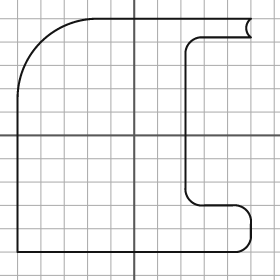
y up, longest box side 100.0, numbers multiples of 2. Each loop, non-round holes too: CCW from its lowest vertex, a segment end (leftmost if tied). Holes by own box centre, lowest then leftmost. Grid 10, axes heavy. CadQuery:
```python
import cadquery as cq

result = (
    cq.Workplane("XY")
    .moveTo(-50.0, -50.0)
    .lineTo(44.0, -50.0)
    .threePointArc((48.0, -48.0), (50.0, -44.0))
    .lineTo(50.0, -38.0)
    .threePointArc((48.0, -32.0), (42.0, -30.0))
    .lineTo(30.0, -30.0)
    .threePointArc((24.0, -28.0), (22.0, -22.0))
    .lineTo(22.0, 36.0)
    .threePointArc((24.0, 40.0), (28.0, 42.0))
    .lineTo(50.0, 42.0)
    .threePointArc((48.0, 46.0), (50.0, 50.0))
    .lineTo(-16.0, 50.0)
    .threePointArc((-40.0, 40.0), (-50.0, 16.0))
    .close()
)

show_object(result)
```